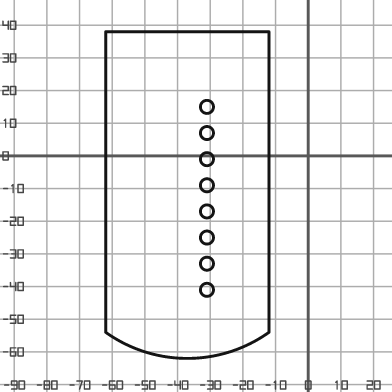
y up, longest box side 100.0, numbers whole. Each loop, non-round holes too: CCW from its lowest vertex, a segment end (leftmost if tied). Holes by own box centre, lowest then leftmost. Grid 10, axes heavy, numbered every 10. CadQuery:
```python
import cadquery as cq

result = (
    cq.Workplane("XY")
    .moveTo(-62.0, -54.0)
    .threePointArc((-37.0, -62.0), (-12.0, -54.0))
    .lineTo(-12.0, 38.0)
    .lineTo(-62.0, 38.0)
    .close()
    .moveTo(-31.0, -41.0)
    .circle(2.0)
    .moveTo(-31.0, -33.0)
    .circle(2.0)
    .moveTo(-31.0, -25.0)
    .circle(2.0)
    .moveTo(-31.0, -17.0)
    .circle(2.0)
    .moveTo(-31.0, -9.0)
    .circle(2.0)
    .moveTo(-31.0, -1.0)
    .circle(2.0)
    .moveTo(-31.0, 7.0)
    .circle(2.0)
    .moveTo(-31.0, 15.0)
    .circle(2.0)
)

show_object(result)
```